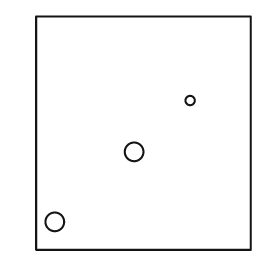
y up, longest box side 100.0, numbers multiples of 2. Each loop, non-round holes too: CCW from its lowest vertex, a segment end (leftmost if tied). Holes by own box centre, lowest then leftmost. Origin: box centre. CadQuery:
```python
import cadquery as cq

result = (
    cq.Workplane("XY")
    .moveTo(-46.0, -50.0)
    .lineTo(46.0, -50.0)
    .lineTo(46.0, 50.0)
    .lineTo(-46.0, 50.0)
    .close()
    .moveTo(-38.0, -38.0)
    .circle(4.0)
    .moveTo(-4.0, -8.0)
    .circle(4.0)
    .moveTo(20.0, 14.0)
    .circle(2.0)
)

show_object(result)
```